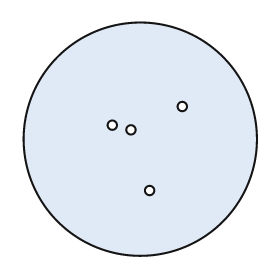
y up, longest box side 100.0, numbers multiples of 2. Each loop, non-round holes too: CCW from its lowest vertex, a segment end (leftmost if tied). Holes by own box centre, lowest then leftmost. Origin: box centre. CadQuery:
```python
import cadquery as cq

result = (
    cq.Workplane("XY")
    .moveTo(0.0, 0.0)
    .circle(50.0)
    .moveTo(4.0, -22.0)
    .circle(2.0)
    .moveTo(-4.0, 4.0)
    .circle(2.0)
    .moveTo(-12.0, 6.0)
    .circle(2.0)
    .moveTo(18.0, 14.0)
    .circle(2.0)
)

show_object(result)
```